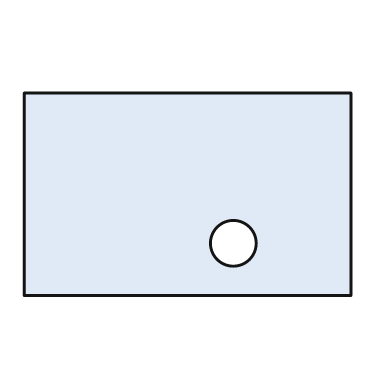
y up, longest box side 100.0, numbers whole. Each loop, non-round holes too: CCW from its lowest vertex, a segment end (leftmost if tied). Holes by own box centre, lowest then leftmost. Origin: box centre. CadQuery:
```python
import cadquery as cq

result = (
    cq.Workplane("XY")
    .moveTo(-50.0, -31.0)
    .lineTo(50.0, -31.0)
    .lineTo(50.0, 31.0)
    .lineTo(-50.0, 31.0)
    .close()
    .moveTo(14.0, -15.0)
    .circle(7.0)
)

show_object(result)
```